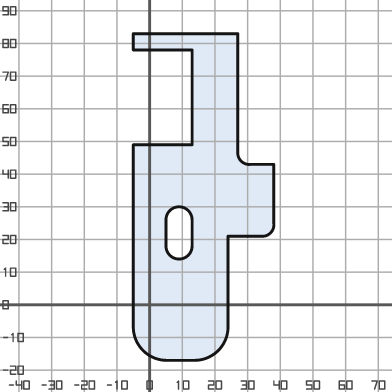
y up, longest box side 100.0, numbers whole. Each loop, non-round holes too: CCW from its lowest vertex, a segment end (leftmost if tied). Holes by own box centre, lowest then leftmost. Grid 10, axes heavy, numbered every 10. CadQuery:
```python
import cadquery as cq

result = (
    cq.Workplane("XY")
    .moveTo(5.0, -17.0)
    .lineTo(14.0, -17.0)
    .threePointArc((21.0, -14.0), (24.0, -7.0))
    .lineTo(24.0, 21.0)
    .lineTo(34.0, 21.0)
    .threePointArc((37.0, 22.0), (38.0, 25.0))
    .lineTo(38.0, 43.0)
    .lineTo(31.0, 43.0)
    .threePointArc((28.0, 44.0), (27.0, 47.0))
    .lineTo(27.0, 83.0)
    .lineTo(-5.0, 83.0)
    .lineTo(-5.0, 78.0)
    .lineTo(13.0, 78.0)
    .lineTo(13.0, 49.0)
    .lineTo(-5.0, 49.0)
    .lineTo(-5.0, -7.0)
    .threePointArc((-2.0, -14.0), (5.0, -17.0))
    .close()
    .moveTo(5.0, 18.0)
    .threePointArc((9.0, 14.0), (13.0, 18.0))
    .lineTo(13.0, 26.0)
    .threePointArc((9.0, 30.0), (5.0, 26.0))
    .close()
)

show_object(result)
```